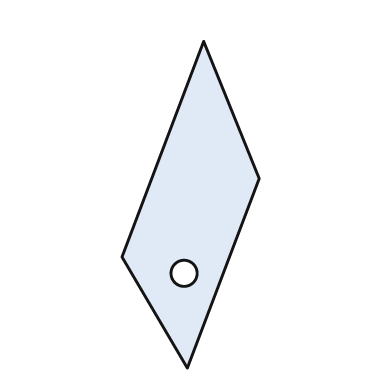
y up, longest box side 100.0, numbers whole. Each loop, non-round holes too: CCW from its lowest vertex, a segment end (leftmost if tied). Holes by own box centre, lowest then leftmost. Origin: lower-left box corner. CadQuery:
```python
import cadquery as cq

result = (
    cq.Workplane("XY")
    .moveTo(20.0, 0.0)
    .lineTo(42.0, 58.0)
    .lineTo(25.0, 100.0)
    .lineTo(0.0, 34.0)
    .close()
    .moveTo(19.0, 29.0)
    .circle(4.0)
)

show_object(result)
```